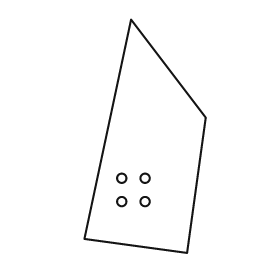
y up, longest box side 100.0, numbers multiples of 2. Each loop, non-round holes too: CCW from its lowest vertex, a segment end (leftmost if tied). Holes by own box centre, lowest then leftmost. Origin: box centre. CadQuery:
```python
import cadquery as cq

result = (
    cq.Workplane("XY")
    .moveTo(18.0, -50.0)
    .lineTo(26.0, 8.0)
    .lineTo(-6.0, 50.0)
    .lineTo(-26.0, -44.0)
    .close()
    .moveTo(-10.0, -28.0)
    .circle(2.0)
    .moveTo(0.0, -28.0)
    .circle(2.0)
    .moveTo(-10.0, -18.0)
    .circle(2.0)
    .moveTo(0.0, -18.0)
    .circle(2.0)
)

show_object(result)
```